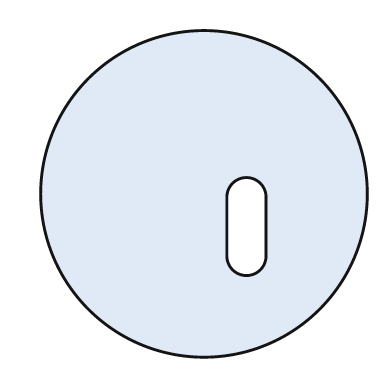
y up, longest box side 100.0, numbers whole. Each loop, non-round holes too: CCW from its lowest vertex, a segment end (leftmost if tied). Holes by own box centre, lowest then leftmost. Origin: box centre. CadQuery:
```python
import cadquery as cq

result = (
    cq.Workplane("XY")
    .moveTo(0.0, 0.0)
    .circle(50.0)
    .moveTo(7.0, -19.0)
    .threePointArc((13.0, -25.0), (19.0, -19.0))
    .lineTo(19.0, -1.0)
    .threePointArc((13.0, 5.0), (7.0, -1.0))
    .close()
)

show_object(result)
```